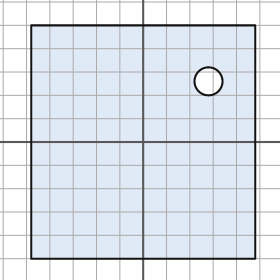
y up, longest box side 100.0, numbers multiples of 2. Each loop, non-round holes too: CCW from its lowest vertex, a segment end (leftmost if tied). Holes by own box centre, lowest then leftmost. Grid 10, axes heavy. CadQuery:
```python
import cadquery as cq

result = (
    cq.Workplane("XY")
    .moveTo(-48.0, -50.0)
    .lineTo(48.0, -50.0)
    .lineTo(48.0, 50.0)
    .lineTo(-48.0, 50.0)
    .close()
    .moveTo(28.0, 26.0)
    .circle(6.0)
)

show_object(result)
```